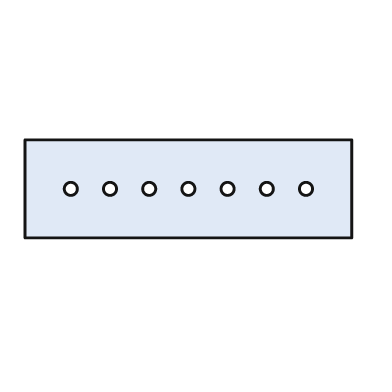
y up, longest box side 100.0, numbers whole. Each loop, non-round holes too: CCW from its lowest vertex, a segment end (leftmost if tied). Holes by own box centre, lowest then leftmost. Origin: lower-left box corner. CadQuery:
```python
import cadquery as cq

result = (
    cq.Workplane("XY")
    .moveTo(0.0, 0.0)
    .lineTo(100.0, 0.0)
    .lineTo(100.0, 30.0)
    .lineTo(0.0, 30.0)
    .close()
    .moveTo(14.0, 15.0)
    .circle(2.0)
    .moveTo(26.0, 15.0)
    .circle(2.0)
    .moveTo(38.0, 15.0)
    .circle(2.0)
    .moveTo(50.0, 15.0)
    .circle(2.0)
    .moveTo(62.0, 15.0)
    .circle(2.0)
    .moveTo(74.0, 15.0)
    .circle(2.0)
    .moveTo(86.0, 15.0)
    .circle(2.0)
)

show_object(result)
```